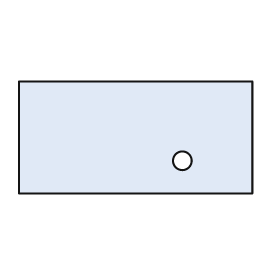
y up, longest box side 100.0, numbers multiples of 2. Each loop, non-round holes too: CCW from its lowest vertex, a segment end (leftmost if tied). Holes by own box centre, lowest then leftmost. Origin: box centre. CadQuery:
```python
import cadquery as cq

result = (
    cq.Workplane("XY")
    .moveTo(-50.0, -24.0)
    .lineTo(50.0, -24.0)
    .lineTo(50.0, 24.0)
    .lineTo(-50.0, 24.0)
    .close()
    .moveTo(20.0, -10.0)
    .circle(4.0)
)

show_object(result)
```